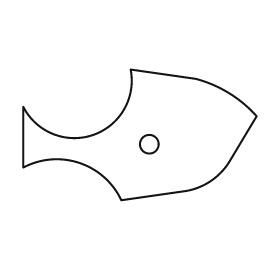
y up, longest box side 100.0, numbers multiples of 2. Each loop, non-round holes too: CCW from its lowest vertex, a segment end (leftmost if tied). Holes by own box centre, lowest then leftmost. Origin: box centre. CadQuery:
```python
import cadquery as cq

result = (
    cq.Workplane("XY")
    .moveTo(-8.0, -28.0)
    .lineTo(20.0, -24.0)
    .threePointArc((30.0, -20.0), (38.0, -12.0))
    .lineTo(50.0, 8.0)
    .threePointArc((38.0, 18.0), (24.0, 24.0))
    .lineTo(-4.0, 28.0)
    .threePointArc((-20.0, 0.0), (-50.0, 12.0))
    .lineTo(-50.0, -14.0)
    .threePointArc((-26.0, -12.0), (-8.0, -28.0))
    .close()
    .moveTo(4.0, -4.0)
    .circle(4.0)
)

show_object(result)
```